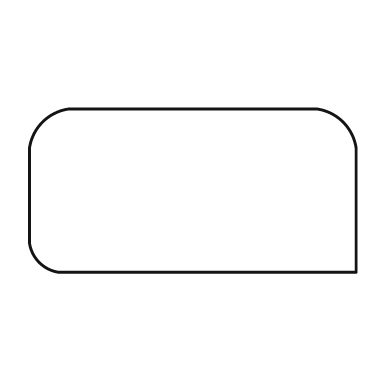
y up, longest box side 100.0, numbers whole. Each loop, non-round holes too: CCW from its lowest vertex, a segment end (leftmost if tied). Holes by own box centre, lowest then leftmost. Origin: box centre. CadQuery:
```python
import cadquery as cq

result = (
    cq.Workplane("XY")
    .moveTo(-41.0, -25.0)
    .lineTo(50.0, -25.0)
    .lineTo(50.0, 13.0)
    .threePointArc((46.0, 21.0), (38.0, 25.0))
    .lineTo(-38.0, 25.0)
    .threePointArc((-46.0, 21.0), (-50.0, 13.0))
    .lineTo(-50.0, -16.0)
    .threePointArc((-47.0, -22.0), (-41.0, -25.0))
    .close()
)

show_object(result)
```